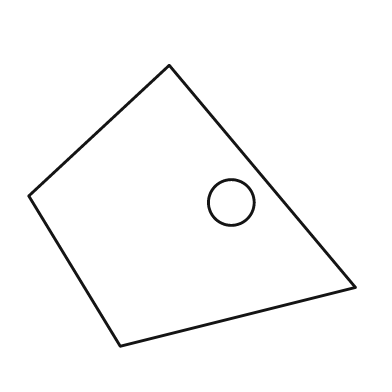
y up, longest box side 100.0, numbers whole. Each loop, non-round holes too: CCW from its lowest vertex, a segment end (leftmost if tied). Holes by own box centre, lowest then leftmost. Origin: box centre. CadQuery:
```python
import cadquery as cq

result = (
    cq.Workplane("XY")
    .moveTo(-22.0, -43.0)
    .lineTo(50.0, -25.0)
    .lineTo(-7.0, 43.0)
    .lineTo(-50.0, 3.0)
    .close()
    .moveTo(12.0, 1.0)
    .circle(7.0)
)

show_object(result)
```